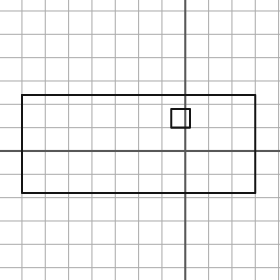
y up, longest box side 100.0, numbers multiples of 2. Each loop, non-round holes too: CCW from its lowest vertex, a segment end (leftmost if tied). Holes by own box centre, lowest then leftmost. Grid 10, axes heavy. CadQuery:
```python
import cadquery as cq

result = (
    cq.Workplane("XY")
    .moveTo(-70.0, -18.0)
    .lineTo(30.0, -18.0)
    .lineTo(30.0, 24.0)
    .lineTo(-70.0, 24.0)
    .close()
    .moveTo(-6.0, 10.0)
    .lineTo(2.0, 10.0)
    .lineTo(2.0, 18.0)
    .lineTo(-6.0, 18.0)
    .close()
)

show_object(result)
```